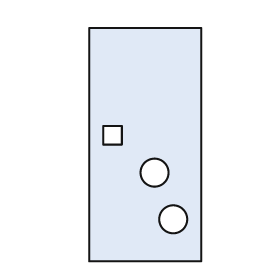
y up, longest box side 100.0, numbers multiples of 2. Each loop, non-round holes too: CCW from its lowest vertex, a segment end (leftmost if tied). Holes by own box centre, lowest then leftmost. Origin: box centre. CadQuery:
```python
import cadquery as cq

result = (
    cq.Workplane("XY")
    .moveTo(-24.0, -50.0)
    .lineTo(24.0, -50.0)
    .lineTo(24.0, 50.0)
    .lineTo(-24.0, 50.0)
    .close()
    .moveTo(12.0, -32.0)
    .circle(6.0)
    .moveTo(4.0, -12.0)
    .circle(6.0)
    .moveTo(-18.0, 0.0)
    .lineTo(-10.0, 0.0)
    .lineTo(-10.0, 8.0)
    .lineTo(-18.0, 8.0)
    .close()
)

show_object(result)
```